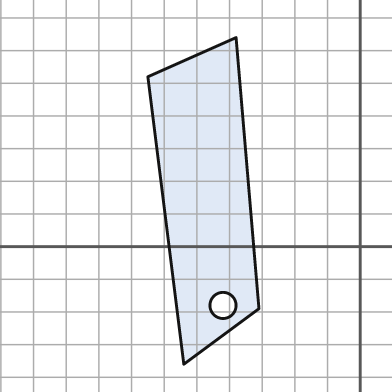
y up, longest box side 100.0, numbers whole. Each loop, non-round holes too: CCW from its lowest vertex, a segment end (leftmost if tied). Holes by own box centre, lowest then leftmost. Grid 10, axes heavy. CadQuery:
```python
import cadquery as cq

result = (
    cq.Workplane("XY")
    .moveTo(-54.0, -36.0)
    .lineTo(-31.0, -19.0)
    .lineTo(-38.0, 64.0)
    .lineTo(-65.0, 52.0)
    .close()
    .moveTo(-42.0, -18.0)
    .circle(4.0)
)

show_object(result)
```